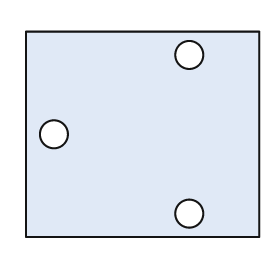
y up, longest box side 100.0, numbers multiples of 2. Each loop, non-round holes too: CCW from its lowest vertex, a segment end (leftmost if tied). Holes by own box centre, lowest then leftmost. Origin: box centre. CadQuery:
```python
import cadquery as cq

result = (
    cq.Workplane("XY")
    .moveTo(-50.0, -44.0)
    .lineTo(50.0, -44.0)
    .lineTo(50.0, 44.0)
    .lineTo(-50.0, 44.0)
    .close()
    .moveTo(20.0, -34.0)
    .circle(6.0)
    .moveTo(-38.0, 0.0)
    .circle(6.0)
    .moveTo(20.0, 34.0)
    .circle(6.0)
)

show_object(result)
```